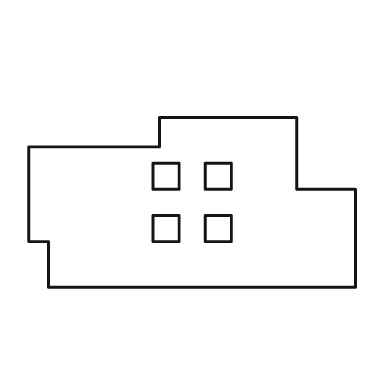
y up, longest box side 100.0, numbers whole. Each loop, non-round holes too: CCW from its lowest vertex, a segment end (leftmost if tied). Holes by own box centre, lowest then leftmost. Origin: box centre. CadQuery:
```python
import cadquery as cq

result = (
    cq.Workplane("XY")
    .moveTo(-44.0, -26.0)
    .lineTo(50.0, -26.0)
    .lineTo(50.0, 4.0)
    .lineTo(32.0, 4.0)
    .lineTo(32.0, 26.0)
    .lineTo(-10.0, 26.0)
    .lineTo(-10.0, 17.0)
    .lineTo(-50.0, 17.0)
    .lineTo(-50.0, -12.0)
    .lineTo(-44.0, -12.0)
    .close()
    .moveTo(-12.0, -12.0)
    .lineTo(-4.0, -12.0)
    .lineTo(-4.0, -4.0)
    .lineTo(-12.0, -4.0)
    .close()
    .moveTo(4.0, -12.0)
    .lineTo(12.0, -12.0)
    .lineTo(12.0, -4.0)
    .lineTo(4.0, -4.0)
    .close()
    .moveTo(-12.0, 4.0)
    .lineTo(-4.0, 4.0)
    .lineTo(-4.0, 12.0)
    .lineTo(-12.0, 12.0)
    .close()
    .moveTo(4.0, 4.0)
    .lineTo(12.0, 4.0)
    .lineTo(12.0, 12.0)
    .lineTo(4.0, 12.0)
    .close()
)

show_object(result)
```